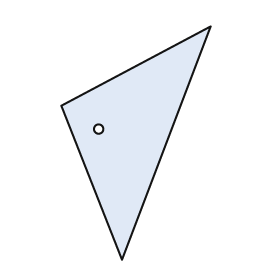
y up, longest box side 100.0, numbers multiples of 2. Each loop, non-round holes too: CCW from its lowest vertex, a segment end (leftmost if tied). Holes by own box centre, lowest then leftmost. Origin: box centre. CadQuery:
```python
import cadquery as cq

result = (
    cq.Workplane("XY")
    .moveTo(-6.0, -50.0)
    .lineTo(32.0, 50.0)
    .lineTo(-32.0, 16.0)
    .close()
    .moveTo(-16.0, 6.0)
    .circle(2.0)
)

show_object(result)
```